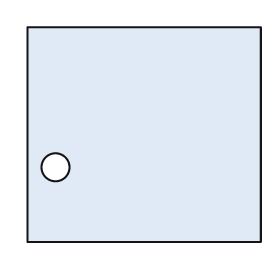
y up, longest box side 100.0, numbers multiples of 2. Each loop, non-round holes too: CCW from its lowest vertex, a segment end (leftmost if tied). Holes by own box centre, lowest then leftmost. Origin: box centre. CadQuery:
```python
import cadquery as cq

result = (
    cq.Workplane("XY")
    .moveTo(-50.0, -46.0)
    .lineTo(50.0, -46.0)
    .lineTo(50.0, 46.0)
    .lineTo(-50.0, 46.0)
    .close()
    .moveTo(-38.0, -14.0)
    .circle(6.0)
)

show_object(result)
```